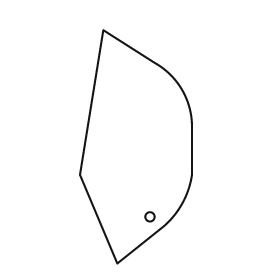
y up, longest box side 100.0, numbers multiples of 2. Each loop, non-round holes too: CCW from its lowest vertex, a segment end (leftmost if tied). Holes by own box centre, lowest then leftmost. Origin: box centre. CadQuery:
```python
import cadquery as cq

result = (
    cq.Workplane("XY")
    .moveTo(-8.0, -50.0)
    .lineTo(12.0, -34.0)
    .threePointArc((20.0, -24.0), (24.0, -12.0))
    .lineTo(24.0, 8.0)
    .threePointArc((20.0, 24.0), (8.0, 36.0))
    .lineTo(-14.0, 50.0)
    .lineTo(-24.0, -12.0)
    .close()
    .moveTo(6.0, -30.0)
    .circle(2.0)
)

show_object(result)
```